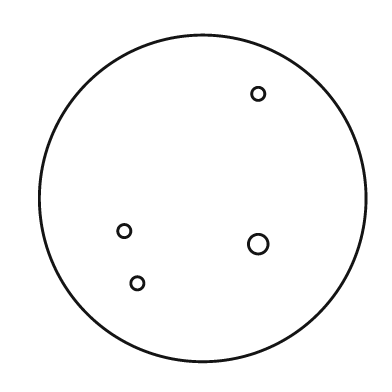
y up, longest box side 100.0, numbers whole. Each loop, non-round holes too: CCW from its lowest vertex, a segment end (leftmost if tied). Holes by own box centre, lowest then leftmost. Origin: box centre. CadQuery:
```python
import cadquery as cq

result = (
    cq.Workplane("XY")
    .moveTo(0.0, 0.0)
    .circle(50.0)
    .moveTo(-20.0, -26.0)
    .circle(2.0)
    .moveTo(17.0, -14.0)
    .circle(3.0)
    .moveTo(-24.0, -10.0)
    .circle(2.0)
    .moveTo(17.0, 32.0)
    .circle(2.0)
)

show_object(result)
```